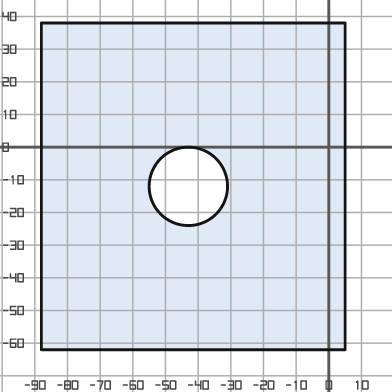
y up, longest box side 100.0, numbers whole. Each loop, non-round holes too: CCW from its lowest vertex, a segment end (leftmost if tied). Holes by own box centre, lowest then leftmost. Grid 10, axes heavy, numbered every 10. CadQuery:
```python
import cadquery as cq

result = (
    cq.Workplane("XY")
    .moveTo(-88.0, -62.0)
    .lineTo(5.0, -62.0)
    .lineTo(5.0, 38.0)
    .lineTo(-88.0, 38.0)
    .close()
    .moveTo(-43.0, -12.0)
    .circle(12.0)
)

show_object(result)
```